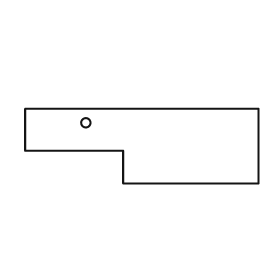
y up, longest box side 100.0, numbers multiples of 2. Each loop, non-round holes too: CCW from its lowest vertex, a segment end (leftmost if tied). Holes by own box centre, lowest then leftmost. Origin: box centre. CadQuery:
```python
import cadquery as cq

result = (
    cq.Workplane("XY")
    .moveTo(-8.0, -16.0)
    .lineTo(50.0, -16.0)
    .lineTo(50.0, 16.0)
    .lineTo(-50.0, 16.0)
    .lineTo(-50.0, -2.0)
    .lineTo(-8.0, -2.0)
    .close()
    .moveTo(-24.0, 10.0)
    .circle(2.0)
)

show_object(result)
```